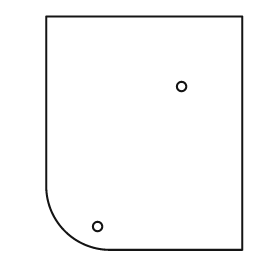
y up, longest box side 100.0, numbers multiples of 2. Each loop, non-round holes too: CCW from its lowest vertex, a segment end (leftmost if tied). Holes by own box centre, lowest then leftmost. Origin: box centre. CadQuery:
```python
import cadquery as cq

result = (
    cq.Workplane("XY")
    .moveTo(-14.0, -50.0)
    .lineTo(42.0, -50.0)
    .lineTo(42.0, 50.0)
    .lineTo(-42.0, 50.0)
    .lineTo(-42.0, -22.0)
    .threePointArc((-34.0, -42.0), (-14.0, -50.0))
    .close()
    .moveTo(-20.0, -40.0)
    .circle(2.0)
    .moveTo(16.0, 20.0)
    .circle(2.0)
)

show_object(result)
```